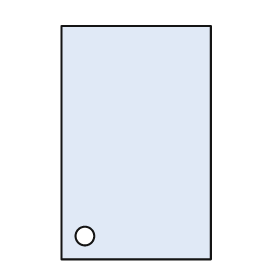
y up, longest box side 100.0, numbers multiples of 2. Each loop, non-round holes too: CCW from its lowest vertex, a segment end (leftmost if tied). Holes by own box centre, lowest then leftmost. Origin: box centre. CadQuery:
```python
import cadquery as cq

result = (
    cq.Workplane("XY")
    .moveTo(-32.0, -50.0)
    .lineTo(32.0, -50.0)
    .lineTo(32.0, 50.0)
    .lineTo(-32.0, 50.0)
    .close()
    .moveTo(-22.0, -40.0)
    .circle(4.0)
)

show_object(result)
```